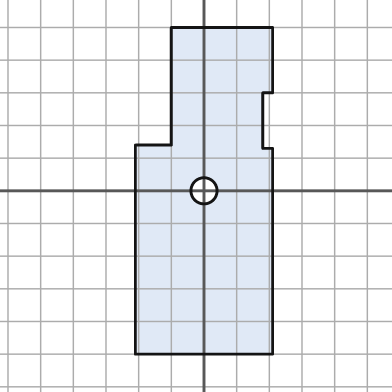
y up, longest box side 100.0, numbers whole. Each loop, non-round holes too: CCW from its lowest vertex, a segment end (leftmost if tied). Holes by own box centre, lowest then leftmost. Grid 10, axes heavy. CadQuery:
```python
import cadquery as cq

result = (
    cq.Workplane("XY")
    .moveTo(-21.0, -50.0)
    .lineTo(21.0, -50.0)
    .lineTo(21.0, 13.0)
    .lineTo(18.0, 13.0)
    .lineTo(18.0, 30.0)
    .lineTo(21.0, 30.0)
    .lineTo(21.0, 50.0)
    .lineTo(-10.0, 50.0)
    .lineTo(-10.0, 14.0)
    .lineTo(-21.0, 14.0)
    .close()
    .moveTo(0.0, 0.0)
    .circle(4.0)
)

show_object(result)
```